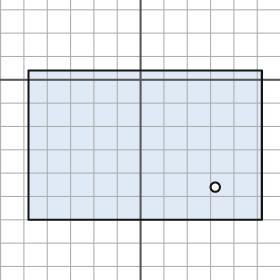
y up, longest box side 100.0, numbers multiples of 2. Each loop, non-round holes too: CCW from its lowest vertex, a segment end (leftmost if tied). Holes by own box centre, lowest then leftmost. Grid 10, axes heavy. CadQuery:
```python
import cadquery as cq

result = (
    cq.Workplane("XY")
    .moveTo(-48.0, -60.0)
    .lineTo(52.0, -60.0)
    .lineTo(52.0, 4.0)
    .lineTo(-48.0, 4.0)
    .close()
    .moveTo(32.0, -46.0)
    .circle(2.0)
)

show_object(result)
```